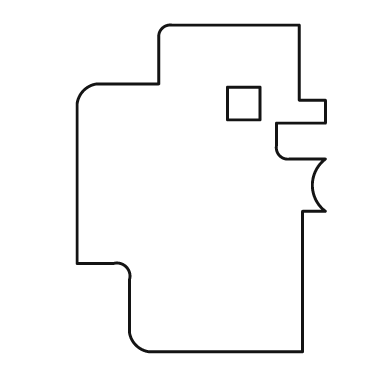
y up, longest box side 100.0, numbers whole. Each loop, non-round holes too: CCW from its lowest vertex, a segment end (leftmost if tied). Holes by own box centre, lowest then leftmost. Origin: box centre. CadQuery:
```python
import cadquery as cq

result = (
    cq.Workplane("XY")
    .moveTo(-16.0, -50.0)
    .lineTo(31.0, -50.0)
    .lineTo(31.0, -7.0)
    .lineTo(38.0, -7.0)
    .threePointArc((34.0, 1.0), (38.0, 9.0))
    .lineTo(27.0, 9.0)
    .threePointArc((24.0, 10.0), (23.0, 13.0))
    .lineTo(23.0, 20.0)
    .lineTo(38.0, 20.0)
    .lineTo(38.0, 27.0)
    .lineTo(30.0, 27.0)
    .lineTo(30.0, 50.0)
    .lineTo(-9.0, 50.0)
    .threePointArc((-12.0, 49.0), (-13.0, 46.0))
    .lineTo(-13.0, 32.0)
    .lineTo(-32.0, 32.0)
    .threePointArc((-36.0, 30.0), (-38.0, 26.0))
    .lineTo(-38.0, -23.0)
    .lineTo(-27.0, -23.0)
    .threePointArc((-23.0, -24.0), (-22.0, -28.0))
    .lineTo(-22.0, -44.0)
    .threePointArc((-20.0, -48.0), (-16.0, -50.0))
    .close()
    .moveTo(8.0, 21.0)
    .lineTo(18.0, 21.0)
    .lineTo(18.0, 31.0)
    .lineTo(8.0, 31.0)
    .close()
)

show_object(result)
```